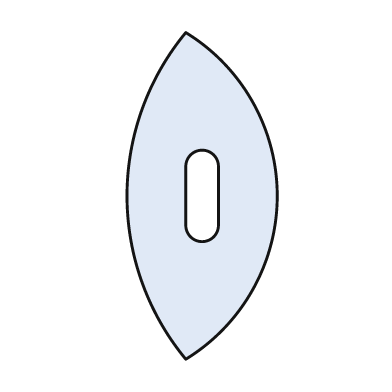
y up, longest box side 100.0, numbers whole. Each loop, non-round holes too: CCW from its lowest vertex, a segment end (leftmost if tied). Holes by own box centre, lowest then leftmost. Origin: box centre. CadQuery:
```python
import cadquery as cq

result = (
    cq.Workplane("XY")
    .moveTo(-5.0, -50.0)
    .threePointArc((23.0, 0.0), (-5.0, 50.0))
    .threePointArc((-23.0, 0.0), (-5.0, -50.0))
    .close()
    .moveTo(-5.0, -9.0)
    .threePointArc((0.0, -14.0), (5.0, -9.0))
    .lineTo(5.0, 9.0)
    .threePointArc((0.0, 14.0), (-5.0, 9.0))
    .close()
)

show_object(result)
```